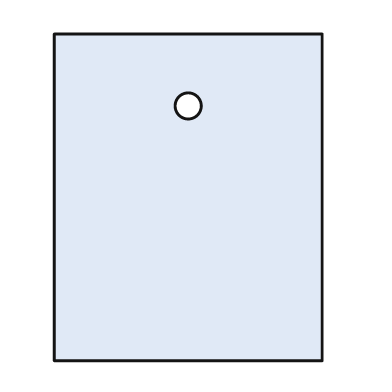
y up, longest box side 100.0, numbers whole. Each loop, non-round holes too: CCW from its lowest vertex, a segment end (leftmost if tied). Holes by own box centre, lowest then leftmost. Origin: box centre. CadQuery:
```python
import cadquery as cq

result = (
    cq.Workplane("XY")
    .moveTo(-41.0, -50.0)
    .lineTo(41.0, -50.0)
    .lineTo(41.0, 50.0)
    .lineTo(-41.0, 50.0)
    .close()
    .moveTo(0.0, 28.0)
    .circle(4.0)
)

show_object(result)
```